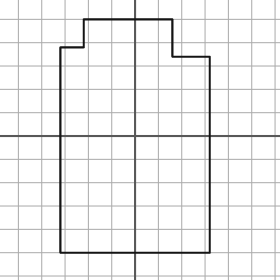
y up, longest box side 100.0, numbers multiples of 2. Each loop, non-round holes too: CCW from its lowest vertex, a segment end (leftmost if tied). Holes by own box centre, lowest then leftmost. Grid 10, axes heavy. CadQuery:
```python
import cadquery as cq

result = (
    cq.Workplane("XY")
    .moveTo(-32.0, -50.0)
    .lineTo(32.0, -50.0)
    .lineTo(32.0, 34.0)
    .lineTo(16.0, 34.0)
    .lineTo(16.0, 50.0)
    .lineTo(-22.0, 50.0)
    .lineTo(-22.0, 38.0)
    .lineTo(-32.0, 38.0)
    .close()
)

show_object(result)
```